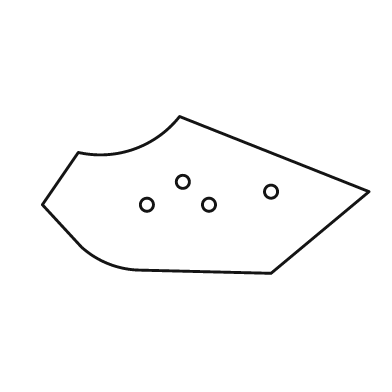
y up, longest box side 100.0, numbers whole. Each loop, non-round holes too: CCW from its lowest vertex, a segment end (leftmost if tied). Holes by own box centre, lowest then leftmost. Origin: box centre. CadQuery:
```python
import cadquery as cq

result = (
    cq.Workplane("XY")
    .moveTo(20.0, -24.0)
    .lineTo(50.0, 1.0)
    .lineTo(-8.0, 24.0)
    .threePointArc((-22.0, 14.0), (-39.0, 13.0))
    .lineTo(-50.0, -3.0)
    .lineTo(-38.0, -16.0)
    .threePointArc((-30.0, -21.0), (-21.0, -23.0))
    .close()
    .moveTo(-18.0, -3.0)
    .circle(2.0)
    .moveTo(1.0, -3.0)
    .circle(2.0)
    .moveTo(20.0, 1.0)
    .circle(2.0)
    .moveTo(-7.0, 4.0)
    .circle(2.0)
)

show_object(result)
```